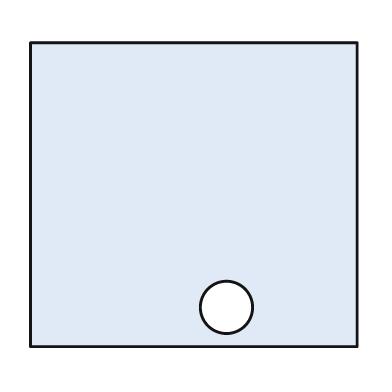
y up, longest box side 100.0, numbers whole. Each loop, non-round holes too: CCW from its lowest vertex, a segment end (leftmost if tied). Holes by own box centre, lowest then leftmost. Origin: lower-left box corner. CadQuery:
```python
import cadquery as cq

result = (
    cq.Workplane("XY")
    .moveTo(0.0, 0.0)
    .lineTo(100.0, 0.0)
    .lineTo(100.0, 93.0)
    .lineTo(0.0, 93.0)
    .close()
    .moveTo(60.0, 12.0)
    .circle(8.0)
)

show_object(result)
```